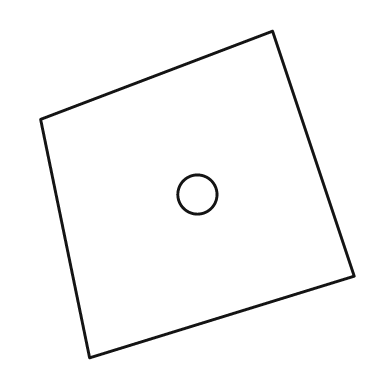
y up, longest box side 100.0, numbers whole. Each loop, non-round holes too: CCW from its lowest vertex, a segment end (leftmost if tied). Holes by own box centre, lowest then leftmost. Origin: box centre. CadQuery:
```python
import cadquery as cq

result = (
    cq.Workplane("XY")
    .moveTo(-33.0, -50.0)
    .lineTo(48.0, -25.0)
    .lineTo(23.0, 50.0)
    .lineTo(-48.0, 23.0)
    .close()
    .moveTo(0.0, 0.0)
    .circle(6.0)
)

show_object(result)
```